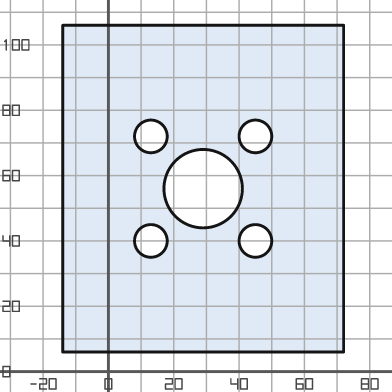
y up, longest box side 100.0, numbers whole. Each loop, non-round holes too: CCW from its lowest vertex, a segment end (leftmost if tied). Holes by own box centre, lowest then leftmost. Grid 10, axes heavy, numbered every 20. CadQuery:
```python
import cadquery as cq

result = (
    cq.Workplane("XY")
    .moveTo(-14.0, 6.0)
    .lineTo(72.0, 6.0)
    .lineTo(72.0, 106.0)
    .lineTo(-14.0, 106.0)
    .close()
    .moveTo(13.0, 40.0)
    .circle(5.0)
    .moveTo(45.0, 40.0)
    .circle(5.0)
    .moveTo(29.0, 56.0)
    .circle(12.0)
    .moveTo(13.0, 72.0)
    .circle(5.0)
    .moveTo(45.0, 72.0)
    .circle(5.0)
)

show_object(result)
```